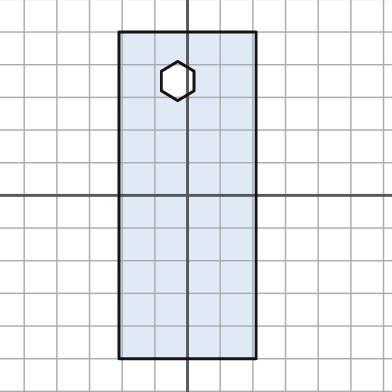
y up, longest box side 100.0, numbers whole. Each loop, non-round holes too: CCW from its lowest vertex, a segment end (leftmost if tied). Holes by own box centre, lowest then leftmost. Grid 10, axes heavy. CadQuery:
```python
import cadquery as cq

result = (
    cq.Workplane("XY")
    .moveTo(-21.0, -50.0)
    .lineTo(21.0, -50.0)
    .lineTo(21.0, 50.0)
    .lineTo(-21.0, 50.0)
    .close()
    .moveTo(-3.0, 29.0)
    .lineTo(2.0, 32.0)
    .lineTo(2.0, 38.0)
    .lineTo(-3.0, 41.0)
    .lineTo(-8.0, 38.0)
    .lineTo(-8.0, 32.0)
    .close()
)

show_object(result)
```